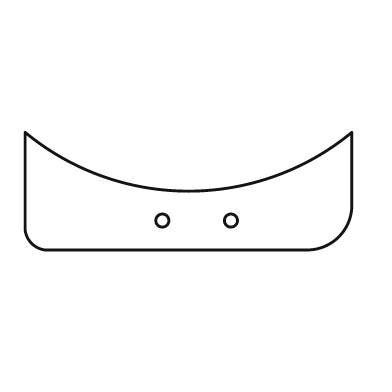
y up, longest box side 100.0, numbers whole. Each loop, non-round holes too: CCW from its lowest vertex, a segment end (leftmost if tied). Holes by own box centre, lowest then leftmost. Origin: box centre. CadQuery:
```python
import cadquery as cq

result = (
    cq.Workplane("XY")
    .moveTo(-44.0, -18.0)
    .lineTo(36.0, -18.0)
    .threePointArc((46.0, -14.0), (50.0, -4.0))
    .lineTo(50.0, 18.0)
    .threePointArc((0.0, 0.0), (-50.0, 18.0))
    .lineTo(-50.0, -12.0)
    .threePointArc((-48.0, -16.0), (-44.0, -18.0))
    .close()
    .moveTo(-8.0, -9.0)
    .circle(2.0)
    .moveTo(13.0, -9.0)
    .circle(2.0)
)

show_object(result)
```